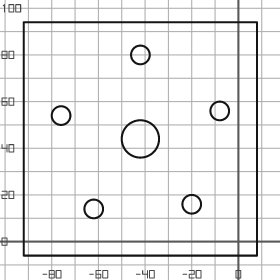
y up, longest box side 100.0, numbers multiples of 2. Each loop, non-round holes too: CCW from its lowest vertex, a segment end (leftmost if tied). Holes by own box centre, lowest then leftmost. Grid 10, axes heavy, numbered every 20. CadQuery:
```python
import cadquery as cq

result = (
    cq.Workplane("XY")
    .moveTo(-92.0, -6.0)
    .lineTo(8.0, -6.0)
    .lineTo(8.0, 94.0)
    .lineTo(-92.0, 94.0)
    .close()
    .moveTo(-62.0, 14.0)
    .circle(4.0)
    .moveTo(-20.0, 16.0)
    .circle(4.0)
    .moveTo(-42.0, 44.0)
    .circle(8.0)
    .moveTo(-76.0, 54.0)
    .circle(4.0)
    .moveTo(-8.0, 56.0)
    .circle(4.0)
    .moveTo(-42.0, 80.0)
    .circle(4.0)
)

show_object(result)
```